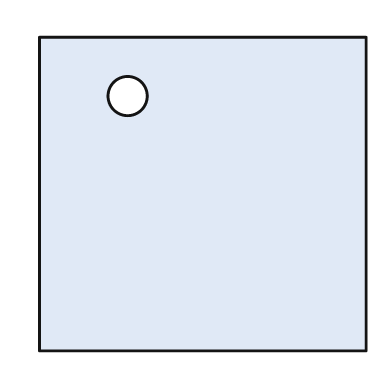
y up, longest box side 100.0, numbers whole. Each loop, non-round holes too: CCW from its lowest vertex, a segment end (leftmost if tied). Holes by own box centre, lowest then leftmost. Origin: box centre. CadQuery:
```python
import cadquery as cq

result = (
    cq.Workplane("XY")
    .moveTo(-50.0, -48.0)
    .lineTo(50.0, -48.0)
    .lineTo(50.0, 48.0)
    .lineTo(-50.0, 48.0)
    .close()
    .moveTo(-23.0, 30.0)
    .circle(6.0)
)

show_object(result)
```